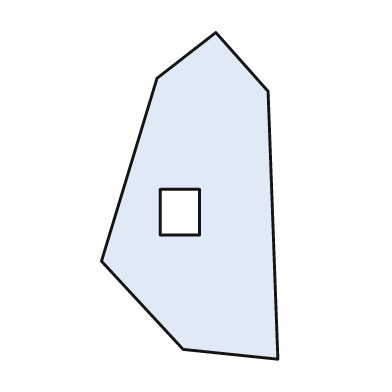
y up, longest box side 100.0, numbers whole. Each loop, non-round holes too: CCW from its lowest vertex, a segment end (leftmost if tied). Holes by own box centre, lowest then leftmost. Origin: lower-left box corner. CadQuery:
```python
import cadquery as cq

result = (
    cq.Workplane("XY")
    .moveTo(54.0, 0.0)
    .lineTo(51.0, 82.0)
    .lineTo(35.0, 100.0)
    .lineTo(17.0, 86.0)
    .lineTo(0.0, 30.0)
    .lineTo(25.0, 3.0)
    .close()
    .moveTo(18.0, 38.0)
    .lineTo(30.0, 38.0)
    .lineTo(30.0, 52.0)
    .lineTo(18.0, 52.0)
    .close()
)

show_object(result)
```